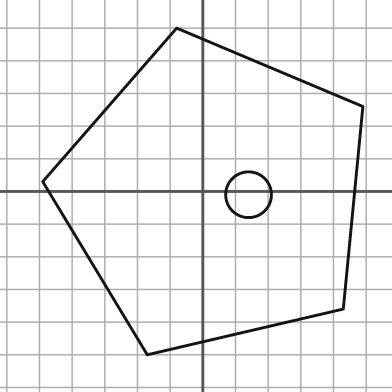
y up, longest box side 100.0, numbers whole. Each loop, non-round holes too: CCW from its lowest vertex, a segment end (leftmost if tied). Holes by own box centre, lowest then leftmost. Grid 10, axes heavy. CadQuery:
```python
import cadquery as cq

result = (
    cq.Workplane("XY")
    .moveTo(-17.0, -50.0)
    .lineTo(43.0, -36.0)
    .lineTo(49.0, 26.0)
    .lineTo(-8.0, 50.0)
    .lineTo(-49.0, 3.0)
    .close()
    .moveTo(14.0, -1.0)
    .circle(7.0)
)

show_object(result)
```